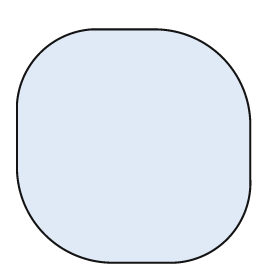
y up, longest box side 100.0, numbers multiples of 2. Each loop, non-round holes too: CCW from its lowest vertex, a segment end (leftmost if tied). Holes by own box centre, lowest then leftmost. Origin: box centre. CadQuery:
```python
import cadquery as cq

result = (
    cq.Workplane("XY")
    .moveTo(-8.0, -50.0)
    .lineTo(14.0, -50.0)
    .threePointArc((40.0, -40.0), (50.0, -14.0))
    .lineTo(50.0, 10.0)
    .threePointArc((38.0, 38.0), (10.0, 50.0))
    .lineTo(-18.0, 50.0)
    .threePointArc((-40.0, 40.0), (-50.0, 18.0))
    .lineTo(-50.0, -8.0)
    .threePointArc((-38.0, -38.0), (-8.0, -50.0))
    .close()
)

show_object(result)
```